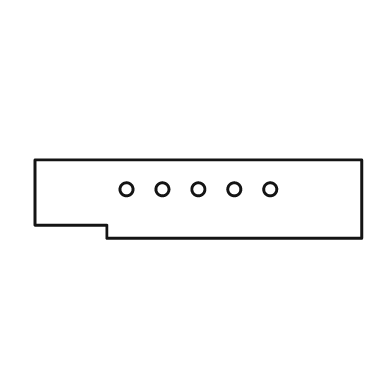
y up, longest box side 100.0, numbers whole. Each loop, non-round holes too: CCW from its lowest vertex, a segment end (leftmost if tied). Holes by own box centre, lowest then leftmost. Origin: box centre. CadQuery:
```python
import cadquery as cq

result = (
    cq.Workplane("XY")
    .moveTo(-28.0, -12.0)
    .lineTo(50.0, -12.0)
    .lineTo(50.0, 12.0)
    .lineTo(-50.0, 12.0)
    .lineTo(-50.0, -8.0)
    .lineTo(-28.0, -8.0)
    .close()
    .moveTo(-22.0, 3.0)
    .circle(2.0)
    .moveTo(-11.0, 3.0)
    .circle(2.0)
    .moveTo(0.0, 3.0)
    .circle(2.0)
    .moveTo(11.0, 3.0)
    .circle(2.0)
    .moveTo(22.0, 3.0)
    .circle(2.0)
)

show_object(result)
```